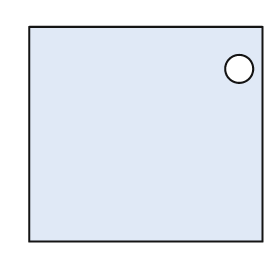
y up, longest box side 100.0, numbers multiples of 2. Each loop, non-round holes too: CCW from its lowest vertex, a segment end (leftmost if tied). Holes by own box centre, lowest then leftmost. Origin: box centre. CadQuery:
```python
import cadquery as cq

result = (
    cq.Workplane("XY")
    .moveTo(-50.0, -46.0)
    .lineTo(50.0, -46.0)
    .lineTo(50.0, 46.0)
    .lineTo(-50.0, 46.0)
    .close()
    .moveTo(40.0, 28.0)
    .circle(6.0)
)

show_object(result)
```